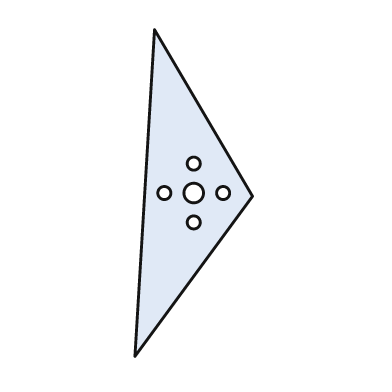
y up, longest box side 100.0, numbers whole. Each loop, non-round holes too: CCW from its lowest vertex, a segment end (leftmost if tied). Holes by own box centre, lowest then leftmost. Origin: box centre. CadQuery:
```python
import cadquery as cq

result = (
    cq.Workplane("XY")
    .moveTo(-18.0, -50.0)
    .lineTo(18.0, -1.0)
    .lineTo(-12.0, 50.0)
    .close()
    .moveTo(0.0, -9.0)
    .circle(2.0)
    .moveTo(-9.0, 0.0)
    .circle(2.0)
    .moveTo(0.0, 0.0)
    .circle(3.0)
    .moveTo(9.0, 0.0)
    .circle(2.0)
    .moveTo(0.0, 9.0)
    .circle(2.0)
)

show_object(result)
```